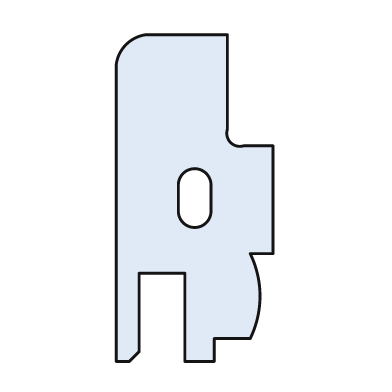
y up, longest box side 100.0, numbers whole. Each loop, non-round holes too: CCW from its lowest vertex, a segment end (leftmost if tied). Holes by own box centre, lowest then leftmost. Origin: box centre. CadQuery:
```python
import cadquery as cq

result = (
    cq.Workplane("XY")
    .moveTo(-24.0, -50.0)
    .lineTo(-20.0, -50.0)
    .lineTo(-17.0, -47.0)
    .lineTo(-17.0, -23.0)
    .lineTo(-3.0, -23.0)
    .lineTo(-3.0, -50.0)
    .lineTo(6.0, -50.0)
    .lineTo(6.0, -43.0)
    .lineTo(17.0, -43.0)
    .threePointArc((20.0, -30.0), (17.0, -17.0))
    .lineTo(24.0, -17.0)
    .lineTo(24.0, 16.0)
    .lineTo(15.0, 16.0)
    .threePointArc((11.0, 17.0), (10.0, 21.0))
    .lineTo(10.0, 50.0)
    .lineTo(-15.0, 50.0)
    .threePointArc((-21.0, 47.0), (-24.0, 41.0))
    .close()
    .moveTo(-5.0, -4.0)
    .threePointArc((0.0, -9.0), (5.0, -4.0))
    .lineTo(5.0, 4.0)
    .threePointArc((0.0, 9.0), (-5.0, 4.0))
    .close()
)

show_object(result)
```